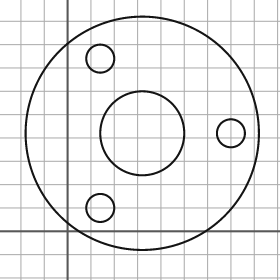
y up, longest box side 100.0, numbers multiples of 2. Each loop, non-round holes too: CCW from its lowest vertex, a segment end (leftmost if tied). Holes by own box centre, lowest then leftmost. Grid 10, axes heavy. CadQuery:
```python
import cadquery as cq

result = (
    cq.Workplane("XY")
    .moveTo(32.0, 42.0)
    .circle(50.0)
    .moveTo(14.0, 10.0)
    .circle(6.0)
    .moveTo(32.0, 42.0)
    .circle(18.0)
    .moveTo(70.0, 42.0)
    .circle(6.0)
    .moveTo(14.0, 74.0)
    .circle(6.0)
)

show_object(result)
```